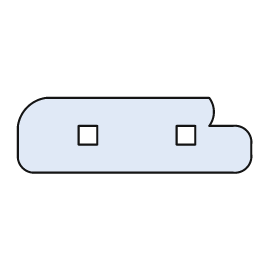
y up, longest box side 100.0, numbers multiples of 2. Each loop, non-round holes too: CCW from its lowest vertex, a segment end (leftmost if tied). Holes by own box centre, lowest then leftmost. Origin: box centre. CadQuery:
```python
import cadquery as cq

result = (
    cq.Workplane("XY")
    .moveTo(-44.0, -16.0)
    .lineTo(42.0, -16.0)
    .threePointArc((48.0, -14.0), (50.0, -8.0))
    .lineTo(50.0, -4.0)
    .threePointArc((48.0, 2.0), (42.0, 4.0))
    .lineTo(32.0, 4.0)
    .threePointArc((34.0, 10.0), (32.0, 16.0))
    .lineTo(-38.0, 16.0)
    .threePointArc((-46.0, 12.0), (-50.0, 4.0))
    .lineTo(-50.0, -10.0)
    .threePointArc((-48.0, -14.0), (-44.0, -16.0))
    .close()
    .moveTo(-24.0, -4.0)
    .lineTo(-16.0, -4.0)
    .lineTo(-16.0, 4.0)
    .lineTo(-24.0, 4.0)
    .close()
    .moveTo(18.0, -4.0)
    .lineTo(26.0, -4.0)
    .lineTo(26.0, 4.0)
    .lineTo(18.0, 4.0)
    .close()
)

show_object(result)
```